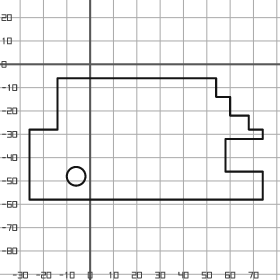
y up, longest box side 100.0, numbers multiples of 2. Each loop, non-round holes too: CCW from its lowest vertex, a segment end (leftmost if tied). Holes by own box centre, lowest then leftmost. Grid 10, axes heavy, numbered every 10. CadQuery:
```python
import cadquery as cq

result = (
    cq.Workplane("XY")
    .moveTo(-26.0, -58.0)
    .lineTo(74.0, -58.0)
    .lineTo(74.0, -46.0)
    .lineTo(58.0, -46.0)
    .lineTo(58.0, -32.0)
    .lineTo(74.0, -32.0)
    .lineTo(74.0, -28.0)
    .lineTo(68.0, -28.0)
    .lineTo(68.0, -22.0)
    .lineTo(60.0, -22.0)
    .lineTo(60.0, -14.0)
    .lineTo(54.0, -14.0)
    .lineTo(54.0, -6.0)
    .lineTo(-14.0, -6.0)
    .lineTo(-14.0, -28.0)
    .lineTo(-26.0, -28.0)
    .close()
    .moveTo(-6.0, -48.0)
    .circle(4.0)
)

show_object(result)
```